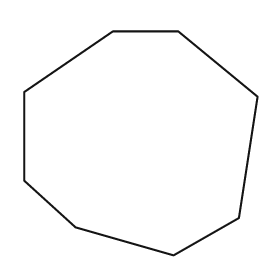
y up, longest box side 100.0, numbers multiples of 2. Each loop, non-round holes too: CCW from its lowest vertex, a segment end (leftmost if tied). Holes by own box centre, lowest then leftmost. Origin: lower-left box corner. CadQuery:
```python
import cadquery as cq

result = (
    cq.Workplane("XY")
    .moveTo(64.0, 0.0)
    .lineTo(92.0, 16.0)
    .lineTo(100.0, 68.0)
    .lineTo(66.0, 96.0)
    .lineTo(38.0, 96.0)
    .lineTo(0.0, 70.0)
    .lineTo(0.0, 32.0)
    .lineTo(22.0, 12.0)
    .close()
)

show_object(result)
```